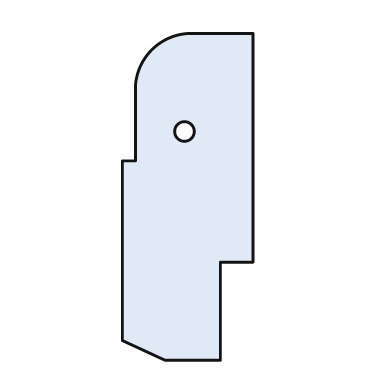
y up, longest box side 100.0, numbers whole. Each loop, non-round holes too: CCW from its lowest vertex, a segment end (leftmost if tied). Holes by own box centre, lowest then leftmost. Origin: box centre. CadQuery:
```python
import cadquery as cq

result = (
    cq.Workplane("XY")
    .moveTo(-7.0, -50.0)
    .lineTo(10.0, -50.0)
    .lineTo(10.0, -20.0)
    .lineTo(20.0, -20.0)
    .lineTo(20.0, 50.0)
    .lineTo(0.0, 50.0)
    .threePointArc((-11.0, 45.0), (-16.0, 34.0))
    .lineTo(-16.0, 11.0)
    .lineTo(-20.0, 11.0)
    .lineTo(-20.0, -44.0)
    .close()
    .moveTo(-1.0, 20.0)
    .circle(3.0)
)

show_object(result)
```